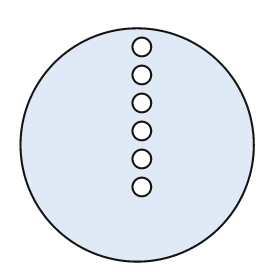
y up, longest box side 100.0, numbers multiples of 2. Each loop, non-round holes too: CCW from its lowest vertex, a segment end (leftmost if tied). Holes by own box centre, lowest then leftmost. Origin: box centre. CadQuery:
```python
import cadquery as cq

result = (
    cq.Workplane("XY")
    .moveTo(0.0, 0.0)
    .circle(50.0)
    .moveTo(2.0, -18.0)
    .circle(4.0)
    .moveTo(2.0, -6.0)
    .circle(4.0)
    .moveTo(2.0, 6.0)
    .circle(4.0)
    .moveTo(2.0, 18.0)
    .circle(4.0)
    .moveTo(2.0, 30.0)
    .circle(4.0)
    .moveTo(2.0, 42.0)
    .circle(4.0)
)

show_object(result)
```